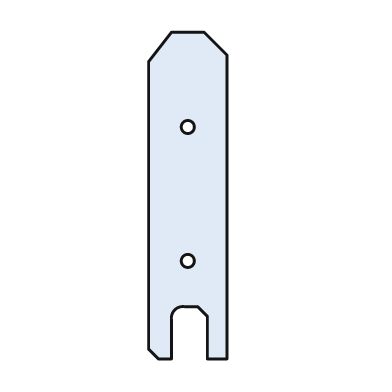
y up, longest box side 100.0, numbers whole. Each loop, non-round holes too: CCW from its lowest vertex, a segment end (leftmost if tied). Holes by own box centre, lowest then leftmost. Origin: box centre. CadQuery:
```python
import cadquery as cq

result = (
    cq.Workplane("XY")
    .moveTo(-9.0, -50.0)
    .lineTo(-5.0, -50.0)
    .lineTo(-5.0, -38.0)
    .threePointArc((-4.0, -35.0), (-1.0, -34.0))
    .lineTo(3.0, -34.0)
    .lineTo(6.0, -37.0)
    .lineTo(6.0, -50.0)
    .lineTo(12.0, -50.0)
    .lineTo(12.0, 43.0)
    .lineTo(5.0, 50.0)
    .lineTo(-5.0, 50.0)
    .lineTo(-12.0, 41.0)
    .lineTo(-12.0, -47.0)
    .close()
    .moveTo(0.0, -20.0)
    .circle(2.0)
    .moveTo(0.0, 21.0)
    .circle(2.0)
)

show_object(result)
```